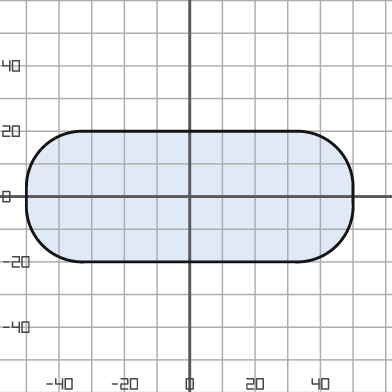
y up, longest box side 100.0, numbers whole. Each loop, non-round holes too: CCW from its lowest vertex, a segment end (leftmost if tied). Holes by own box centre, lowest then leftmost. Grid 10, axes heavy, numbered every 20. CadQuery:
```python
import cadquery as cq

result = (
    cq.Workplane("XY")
    .moveTo(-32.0, -20.0)
    .lineTo(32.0, -20.0)
    .threePointArc((45.0, -15.0), (50.0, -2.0))
    .lineTo(50.0, 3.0)
    .threePointArc((45.0, 15.0), (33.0, 20.0))
    .lineTo(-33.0, 20.0)
    .threePointArc((-45.0, 15.0), (-50.0, 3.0))
    .lineTo(-50.0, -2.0)
    .threePointArc((-45.0, -15.0), (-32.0, -20.0))
    .close()
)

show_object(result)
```